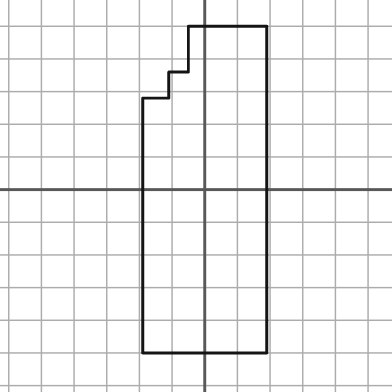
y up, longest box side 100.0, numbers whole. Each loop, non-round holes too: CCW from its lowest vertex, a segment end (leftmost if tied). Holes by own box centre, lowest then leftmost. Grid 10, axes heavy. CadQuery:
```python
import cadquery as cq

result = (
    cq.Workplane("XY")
    .moveTo(-19.0, -50.0)
    .lineTo(19.0, -50.0)
    .lineTo(19.0, 50.0)
    .lineTo(-5.0, 50.0)
    .lineTo(-5.0, 36.0)
    .lineTo(-11.0, 36.0)
    .lineTo(-11.0, 28.0)
    .lineTo(-19.0, 28.0)
    .close()
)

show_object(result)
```